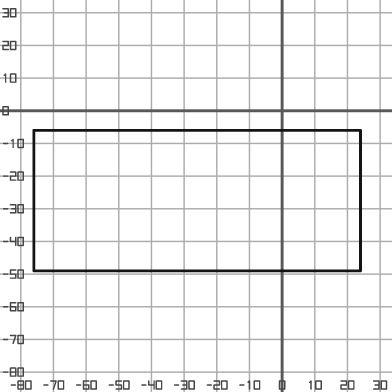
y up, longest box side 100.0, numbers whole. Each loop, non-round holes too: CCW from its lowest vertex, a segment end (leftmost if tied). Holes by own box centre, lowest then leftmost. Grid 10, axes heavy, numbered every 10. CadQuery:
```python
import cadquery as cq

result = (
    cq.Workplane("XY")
    .moveTo(-76.0, -49.0)
    .lineTo(24.0, -49.0)
    .lineTo(24.0, -6.0)
    .lineTo(-76.0, -6.0)
    .close()
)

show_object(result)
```